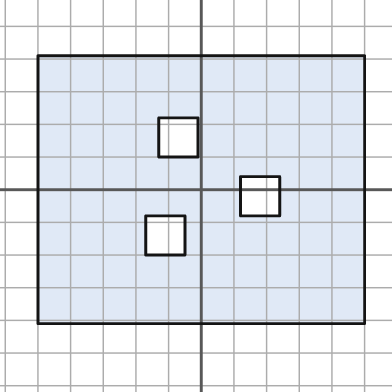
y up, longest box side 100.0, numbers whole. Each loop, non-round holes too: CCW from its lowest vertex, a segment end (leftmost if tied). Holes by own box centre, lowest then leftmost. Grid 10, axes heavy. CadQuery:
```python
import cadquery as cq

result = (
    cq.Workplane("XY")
    .moveTo(-50.0, -41.0)
    .lineTo(50.0, -41.0)
    .lineTo(50.0, 41.0)
    .lineTo(-50.0, 41.0)
    .close()
    .moveTo(-17.0, -20.0)
    .lineTo(-5.0, -20.0)
    .lineTo(-5.0, -8.0)
    .lineTo(-17.0, -8.0)
    .close()
    .moveTo(12.0, -8.0)
    .lineTo(24.0, -8.0)
    .lineTo(24.0, 4.0)
    .lineTo(12.0, 4.0)
    .close()
    .moveTo(-13.0, 10.0)
    .lineTo(-1.0, 10.0)
    .lineTo(-1.0, 22.0)
    .lineTo(-13.0, 22.0)
    .close()
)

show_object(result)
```